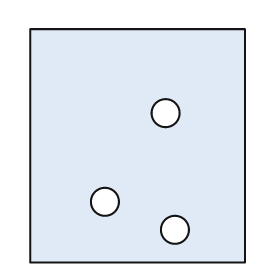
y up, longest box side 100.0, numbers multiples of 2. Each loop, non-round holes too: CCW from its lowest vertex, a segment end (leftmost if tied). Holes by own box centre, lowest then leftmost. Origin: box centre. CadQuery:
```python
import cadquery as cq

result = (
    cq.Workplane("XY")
    .moveTo(-46.0, -50.0)
    .lineTo(46.0, -50.0)
    .lineTo(46.0, 50.0)
    .lineTo(-46.0, 50.0)
    .close()
    .moveTo(16.0, -36.0)
    .circle(6.0)
    .moveTo(-14.0, -24.0)
    .circle(6.0)
    .moveTo(12.0, 14.0)
    .circle(6.0)
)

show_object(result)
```